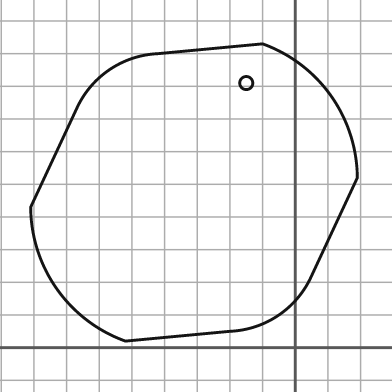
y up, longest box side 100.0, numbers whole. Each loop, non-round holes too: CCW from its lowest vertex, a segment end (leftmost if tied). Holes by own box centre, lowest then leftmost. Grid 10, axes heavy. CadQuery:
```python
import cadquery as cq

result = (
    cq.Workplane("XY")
    .moveTo(-52.0, 2.0)
    .lineTo(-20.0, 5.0)
    .threePointArc((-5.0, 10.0), (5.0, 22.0))
    .lineTo(19.0, 52.0)
    .threePointArc((11.0, 77.0), (-10.0, 93.0))
    .lineTo(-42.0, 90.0)
    .threePointArc((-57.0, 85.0), (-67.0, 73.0))
    .lineTo(-81.0, 43.0)
    .threePointArc((-73.0, 18.0), (-52.0, 2.0))
    .close()
    .moveTo(-15.0, 81.0)
    .circle(2.0)
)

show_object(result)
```